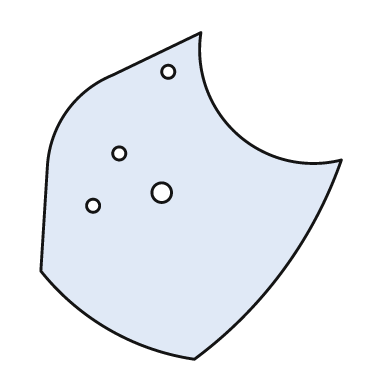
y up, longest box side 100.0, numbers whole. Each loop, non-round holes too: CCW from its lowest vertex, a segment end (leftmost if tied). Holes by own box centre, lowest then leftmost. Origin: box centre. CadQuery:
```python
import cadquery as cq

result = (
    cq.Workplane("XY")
    .moveTo(1.0, -50.0)
    .threePointArc((28.0, -23.0), (46.0, 11.0))
    .threePointArc((14.0, 19.0), (3.0, 50.0))
    .lineTo(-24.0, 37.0)
    .threePointArc((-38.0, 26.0), (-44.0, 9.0))
    .lineTo(-46.0, -23.0)
    .threePointArc((-25.0, -41.0), (1.0, -50.0))
    .close()
    .moveTo(-30.0, -3.0)
    .circle(2.0)
    .moveTo(-9.0, 1.0)
    .circle(3.0)
    .moveTo(-22.0, 13.0)
    .circle(2.0)
    .moveTo(-7.0, 38.0)
    .circle(2.0)
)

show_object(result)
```